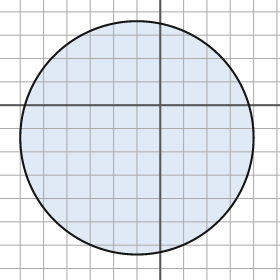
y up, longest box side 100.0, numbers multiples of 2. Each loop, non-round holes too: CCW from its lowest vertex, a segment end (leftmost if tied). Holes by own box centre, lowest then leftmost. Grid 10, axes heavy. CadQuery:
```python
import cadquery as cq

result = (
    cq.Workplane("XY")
    .moveTo(-10.0, -14.0)
    .circle(50.0)
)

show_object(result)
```